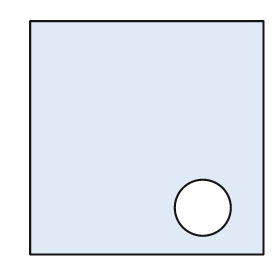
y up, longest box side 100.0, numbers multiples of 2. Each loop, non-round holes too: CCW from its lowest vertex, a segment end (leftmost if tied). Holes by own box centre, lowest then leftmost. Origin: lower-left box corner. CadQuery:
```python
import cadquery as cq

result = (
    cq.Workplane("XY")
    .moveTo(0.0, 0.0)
    .lineTo(100.0, 0.0)
    .lineTo(100.0, 100.0)
    .lineTo(0.0, 100.0)
    .close()
    .moveTo(74.0, 20.0)
    .circle(12.0)
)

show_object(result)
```